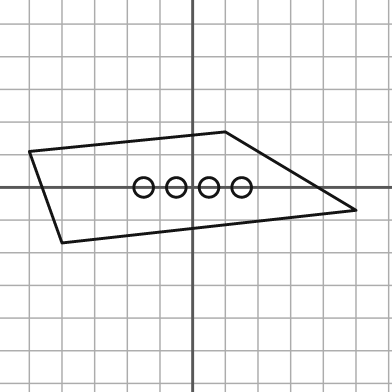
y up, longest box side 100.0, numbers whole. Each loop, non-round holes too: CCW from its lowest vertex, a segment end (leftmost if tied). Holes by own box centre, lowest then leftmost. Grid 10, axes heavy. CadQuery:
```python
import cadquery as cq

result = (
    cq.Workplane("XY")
    .moveTo(-40.0, -17.0)
    .lineTo(50.0, -7.0)
    .lineTo(10.0, 17.0)
    .lineTo(-50.0, 11.0)
    .close()
    .moveTo(-15.0, 0.0)
    .circle(3.0)
    .moveTo(-5.0, 0.0)
    .circle(3.0)
    .moveTo(5.0, 0.0)
    .circle(3.0)
    .moveTo(15.0, 0.0)
    .circle(3.0)
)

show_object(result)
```